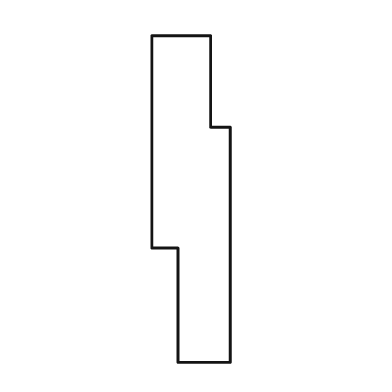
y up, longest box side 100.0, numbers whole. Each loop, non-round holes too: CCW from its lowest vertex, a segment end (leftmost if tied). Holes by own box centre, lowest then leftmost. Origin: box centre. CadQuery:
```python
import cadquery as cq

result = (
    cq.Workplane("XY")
    .moveTo(-4.0, -50.0)
    .lineTo(12.0, -50.0)
    .lineTo(12.0, 22.0)
    .lineTo(6.0, 22.0)
    .lineTo(6.0, 50.0)
    .lineTo(-12.0, 50.0)
    .lineTo(-12.0, -15.0)
    .lineTo(-4.0, -15.0)
    .close()
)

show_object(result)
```